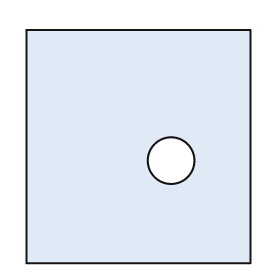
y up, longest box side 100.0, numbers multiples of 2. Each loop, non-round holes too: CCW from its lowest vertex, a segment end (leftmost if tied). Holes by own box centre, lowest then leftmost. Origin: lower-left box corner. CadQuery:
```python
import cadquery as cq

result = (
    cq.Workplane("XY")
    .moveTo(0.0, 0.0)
    .lineTo(96.0, 0.0)
    .lineTo(96.0, 100.0)
    .lineTo(0.0, 100.0)
    .close()
    .moveTo(62.0, 44.0)
    .circle(10.0)
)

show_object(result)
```